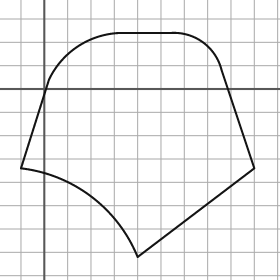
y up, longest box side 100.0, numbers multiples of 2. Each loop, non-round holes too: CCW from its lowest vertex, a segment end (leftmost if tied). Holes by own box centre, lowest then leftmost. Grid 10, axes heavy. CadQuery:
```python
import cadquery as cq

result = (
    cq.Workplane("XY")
    .moveTo(40.0, -72.0)
    .lineTo(90.0, -34.0)
    .lineTo(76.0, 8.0)
    .threePointArc((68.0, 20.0), (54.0, 24.0))
    .lineTo(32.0, 24.0)
    .threePointArc((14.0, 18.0), (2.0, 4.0))
    .lineTo(-10.0, -34.0)
    .threePointArc((20.0, -46.0), (40.0, -72.0))
    .close()
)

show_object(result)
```